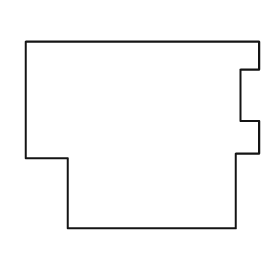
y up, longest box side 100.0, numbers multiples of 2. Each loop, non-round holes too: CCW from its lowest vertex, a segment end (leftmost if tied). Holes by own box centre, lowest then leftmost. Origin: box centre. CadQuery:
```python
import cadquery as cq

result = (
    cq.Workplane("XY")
    .moveTo(-32.0, -40.0)
    .lineTo(40.0, -40.0)
    .lineTo(40.0, -8.0)
    .lineTo(50.0, -8.0)
    .lineTo(50.0, 6.0)
    .lineTo(42.0, 6.0)
    .lineTo(42.0, 28.0)
    .lineTo(50.0, 28.0)
    .lineTo(50.0, 40.0)
    .lineTo(-50.0, 40.0)
    .lineTo(-50.0, -10.0)
    .lineTo(-32.0, -10.0)
    .close()
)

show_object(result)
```